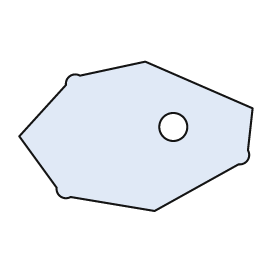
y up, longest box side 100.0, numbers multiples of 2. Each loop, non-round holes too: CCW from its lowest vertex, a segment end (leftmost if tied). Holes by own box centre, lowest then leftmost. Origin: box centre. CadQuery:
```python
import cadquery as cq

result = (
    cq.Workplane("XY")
    .moveTo(8.0, -32.0)
    .lineTo(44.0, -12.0)
    .threePointArc((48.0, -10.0), (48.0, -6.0))
    .lineTo(50.0, 12.0)
    .lineTo(4.0, 32.0)
    .lineTo(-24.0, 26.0)
    .threePointArc((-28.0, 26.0), (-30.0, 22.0))
    .lineTo(-50.0, 0.0)
    .lineTo(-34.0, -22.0)
    .threePointArc((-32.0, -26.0), (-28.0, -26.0))
    .close()
    .moveTo(16.0, 4.0)
    .circle(6.0)
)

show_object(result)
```